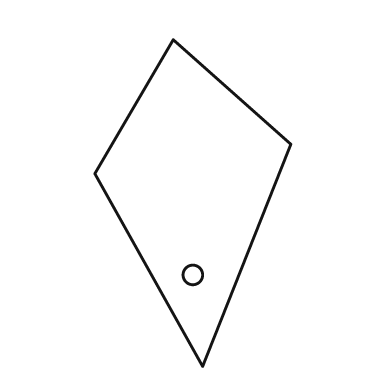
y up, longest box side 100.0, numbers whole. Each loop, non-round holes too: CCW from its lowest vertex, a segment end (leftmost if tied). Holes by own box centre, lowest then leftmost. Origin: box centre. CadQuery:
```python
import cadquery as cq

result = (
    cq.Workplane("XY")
    .moveTo(3.0, -50.0)
    .lineTo(30.0, 18.0)
    .lineTo(-6.0, 50.0)
    .lineTo(-30.0, 9.0)
    .close()
    .moveTo(0.0, -22.0)
    .circle(3.0)
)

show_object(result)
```